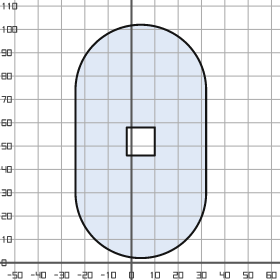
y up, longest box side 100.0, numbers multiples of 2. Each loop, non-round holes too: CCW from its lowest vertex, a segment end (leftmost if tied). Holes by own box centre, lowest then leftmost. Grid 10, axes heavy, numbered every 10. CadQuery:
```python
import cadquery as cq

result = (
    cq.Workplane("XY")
    .moveTo(-24.0, 30.0)
    .threePointArc((4.0, 2.0), (32.0, 30.0))
    .lineTo(32.0, 74.0)
    .threePointArc((4.0, 102.0), (-24.0, 74.0))
    .close()
    .moveTo(-2.0, 46.0)
    .lineTo(10.0, 46.0)
    .lineTo(10.0, 58.0)
    .lineTo(-2.0, 58.0)
    .close()
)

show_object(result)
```